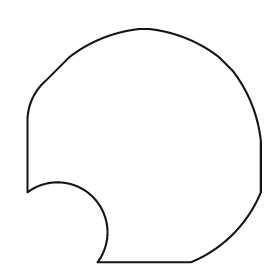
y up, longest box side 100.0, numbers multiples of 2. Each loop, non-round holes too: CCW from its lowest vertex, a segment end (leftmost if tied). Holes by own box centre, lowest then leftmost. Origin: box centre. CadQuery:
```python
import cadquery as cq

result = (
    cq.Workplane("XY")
    .moveTo(-20.0, -50.0)
    .lineTo(20.0, -50.0)
    .threePointArc((38.0, -38.0), (50.0, -20.0))
    .lineTo(50.0, 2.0)
    .threePointArc((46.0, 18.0), (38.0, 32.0))
    .lineTo(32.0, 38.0)
    .threePointArc((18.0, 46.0), (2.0, 50.0))
    .lineTo(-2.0, 50.0)
    .threePointArc((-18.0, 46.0), (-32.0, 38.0))
    .lineTo(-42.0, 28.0)
    .threePointArc((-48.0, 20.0), (-50.0, 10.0))
    .lineTo(-50.0, -20.0)
    .threePointArc((-22.0, -22.0), (-20.0, -50.0))
    .close()
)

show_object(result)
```